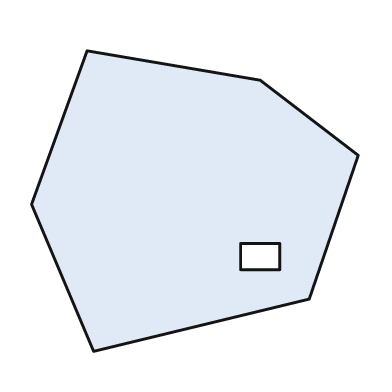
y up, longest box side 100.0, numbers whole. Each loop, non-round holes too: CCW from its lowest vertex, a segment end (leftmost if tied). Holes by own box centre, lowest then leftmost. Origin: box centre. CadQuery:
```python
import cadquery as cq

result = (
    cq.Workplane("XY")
    .moveTo(-31.0, -46.0)
    .lineTo(35.0, -30.0)
    .lineTo(50.0, 14.0)
    .lineTo(20.0, 37.0)
    .lineTo(-33.0, 46.0)
    .lineTo(-50.0, -1.0)
    .close()
    .moveTo(14.0, -21.0)
    .lineTo(26.0, -21.0)
    .lineTo(26.0, -13.0)
    .lineTo(14.0, -13.0)
    .close()
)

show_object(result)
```